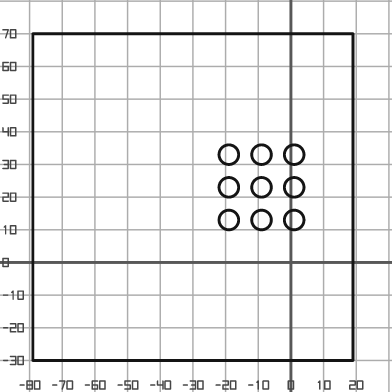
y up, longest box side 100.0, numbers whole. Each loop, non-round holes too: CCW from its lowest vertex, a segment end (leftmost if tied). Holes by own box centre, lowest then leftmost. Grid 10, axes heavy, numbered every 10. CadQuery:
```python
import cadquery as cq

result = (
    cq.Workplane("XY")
    .moveTo(-79.0, -30.0)
    .lineTo(19.0, -30.0)
    .lineTo(19.0, 70.0)
    .lineTo(-79.0, 70.0)
    .close()
    .moveTo(-19.0, 13.0)
    .circle(3.0)
    .moveTo(-9.0, 13.0)
    .circle(3.0)
    .moveTo(1.0, 13.0)
    .circle(3.0)
    .moveTo(-19.0, 23.0)
    .circle(3.0)
    .moveTo(-9.0, 23.0)
    .circle(3.0)
    .moveTo(1.0, 23.0)
    .circle(3.0)
    .moveTo(-19.0, 33.0)
    .circle(3.0)
    .moveTo(-9.0, 33.0)
    .circle(3.0)
    .moveTo(1.0, 33.0)
    .circle(3.0)
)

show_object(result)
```